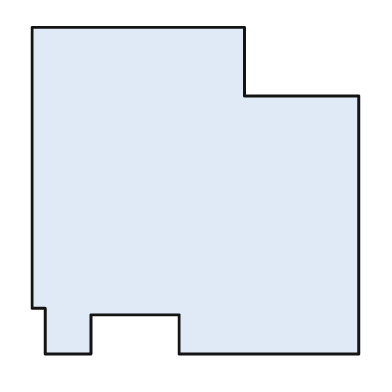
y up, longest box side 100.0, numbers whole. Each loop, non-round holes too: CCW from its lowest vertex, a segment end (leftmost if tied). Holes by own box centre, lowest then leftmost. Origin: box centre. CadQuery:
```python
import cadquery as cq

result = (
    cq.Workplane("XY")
    .moveTo(-46.0, -50.0)
    .lineTo(-32.0, -50.0)
    .lineTo(-32.0, -38.0)
    .lineTo(-5.0, -38.0)
    .lineTo(-5.0, -50.0)
    .lineTo(50.0, -50.0)
    .lineTo(50.0, 29.0)
    .lineTo(15.0, 29.0)
    .lineTo(15.0, 50.0)
    .lineTo(-50.0, 50.0)
    .lineTo(-50.0, -36.0)
    .lineTo(-46.0, -36.0)
    .close()
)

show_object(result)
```